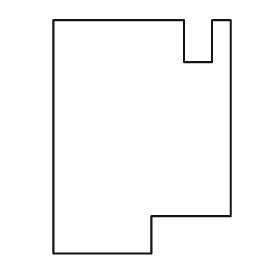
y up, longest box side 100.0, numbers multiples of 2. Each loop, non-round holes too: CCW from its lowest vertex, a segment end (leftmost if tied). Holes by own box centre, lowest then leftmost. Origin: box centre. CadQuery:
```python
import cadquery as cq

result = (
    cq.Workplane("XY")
    .moveTo(-38.0, -50.0)
    .lineTo(4.0, -50.0)
    .lineTo(4.0, -34.0)
    .lineTo(38.0, -34.0)
    .lineTo(38.0, 50.0)
    .lineTo(30.0, 50.0)
    .lineTo(30.0, 32.0)
    .lineTo(18.0, 32.0)
    .lineTo(18.0, 50.0)
    .lineTo(-38.0, 50.0)
    .close()
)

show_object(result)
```